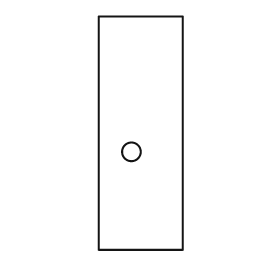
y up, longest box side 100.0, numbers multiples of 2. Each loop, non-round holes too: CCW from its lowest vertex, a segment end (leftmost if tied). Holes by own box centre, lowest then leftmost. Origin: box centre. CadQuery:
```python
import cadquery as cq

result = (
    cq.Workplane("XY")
    .moveTo(-18.0, -50.0)
    .lineTo(18.0, -50.0)
    .lineTo(18.0, 50.0)
    .lineTo(-18.0, 50.0)
    .close()
    .moveTo(-4.0, -8.0)
    .circle(4.0)
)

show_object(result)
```